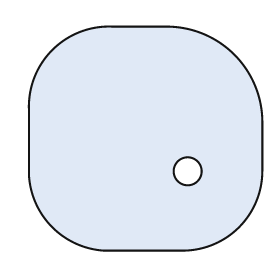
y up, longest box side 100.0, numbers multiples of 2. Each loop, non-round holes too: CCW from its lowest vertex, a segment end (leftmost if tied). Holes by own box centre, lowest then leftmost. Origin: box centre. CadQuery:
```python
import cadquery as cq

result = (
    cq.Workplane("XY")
    .moveTo(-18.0, -48.0)
    .lineTo(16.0, -48.0)
    .threePointArc((40.0, -38.0), (50.0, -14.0))
    .lineTo(50.0, 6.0)
    .threePointArc((38.0, 36.0), (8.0, 48.0))
    .lineTo(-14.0, 48.0)
    .threePointArc((-40.0, 38.0), (-50.0, 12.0))
    .lineTo(-50.0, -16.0)
    .threePointArc((-40.0, -38.0), (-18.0, -48.0))
    .close()
    .moveTo(18.0, -14.0)
    .circle(6.0)
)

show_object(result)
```